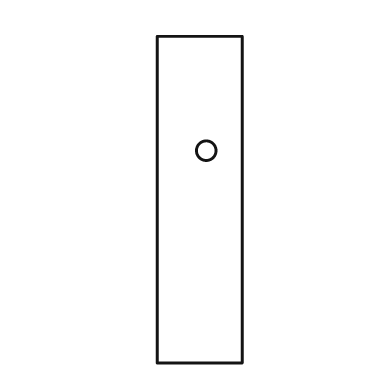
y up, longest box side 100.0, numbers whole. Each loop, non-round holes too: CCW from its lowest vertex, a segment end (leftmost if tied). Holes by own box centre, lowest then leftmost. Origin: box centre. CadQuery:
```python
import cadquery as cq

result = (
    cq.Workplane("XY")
    .moveTo(-13.0, -50.0)
    .lineTo(13.0, -50.0)
    .lineTo(13.0, 50.0)
    .lineTo(-13.0, 50.0)
    .close()
    .moveTo(2.0, 15.0)
    .circle(3.0)
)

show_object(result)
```